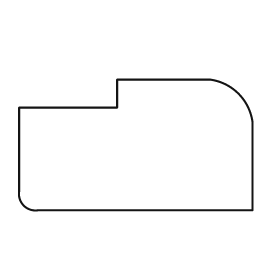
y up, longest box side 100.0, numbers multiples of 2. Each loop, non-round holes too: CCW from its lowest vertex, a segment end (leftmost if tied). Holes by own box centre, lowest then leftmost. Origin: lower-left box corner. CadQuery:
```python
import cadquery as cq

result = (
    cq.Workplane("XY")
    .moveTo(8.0, 0.0)
    .lineTo(100.0, 0.0)
    .lineTo(100.0, 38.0)
    .threePointArc((94.0, 50.0), (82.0, 56.0))
    .lineTo(42.0, 56.0)
    .lineTo(42.0, 44.0)
    .lineTo(0.0, 44.0)
    .lineTo(0.0, 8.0)
    .threePointArc((2.0, 2.0), (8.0, 0.0))
    .close()
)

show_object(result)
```